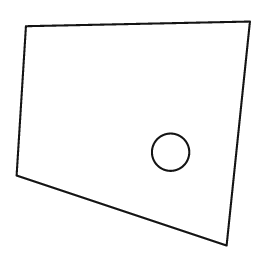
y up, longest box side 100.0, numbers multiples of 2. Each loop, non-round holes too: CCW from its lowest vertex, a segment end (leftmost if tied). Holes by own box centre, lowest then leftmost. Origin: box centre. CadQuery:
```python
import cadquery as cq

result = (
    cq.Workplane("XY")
    .moveTo(40.0, -48.0)
    .lineTo(50.0, 48.0)
    .lineTo(-46.0, 46.0)
    .lineTo(-50.0, -18.0)
    .close()
    .moveTo(16.0, -8.0)
    .circle(8.0)
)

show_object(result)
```